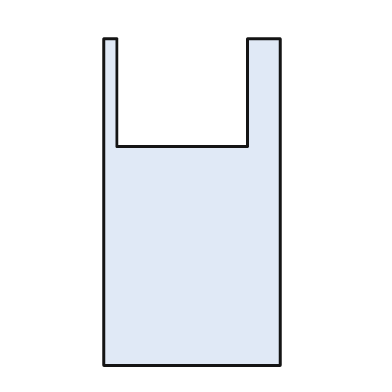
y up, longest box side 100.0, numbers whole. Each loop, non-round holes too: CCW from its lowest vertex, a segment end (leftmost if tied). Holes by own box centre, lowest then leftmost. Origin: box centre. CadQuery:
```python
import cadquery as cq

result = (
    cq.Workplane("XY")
    .moveTo(-27.0, -50.0)
    .lineTo(27.0, -50.0)
    .lineTo(27.0, 50.0)
    .lineTo(17.0, 50.0)
    .lineTo(17.0, 17.0)
    .lineTo(-23.0, 17.0)
    .lineTo(-23.0, 50.0)
    .lineTo(-27.0, 50.0)
    .close()
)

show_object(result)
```